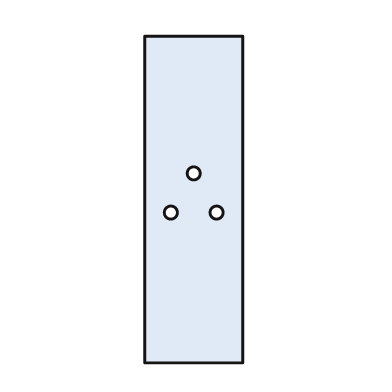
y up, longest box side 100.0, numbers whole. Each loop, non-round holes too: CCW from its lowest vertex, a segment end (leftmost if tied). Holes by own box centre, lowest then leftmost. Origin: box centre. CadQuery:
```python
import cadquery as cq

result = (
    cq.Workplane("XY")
    .moveTo(-15.0, -50.0)
    .lineTo(15.0, -50.0)
    .lineTo(15.0, 50.0)
    .lineTo(-15.0, 50.0)
    .close()
    .moveTo(-7.0, -4.0)
    .circle(2.0)
    .moveTo(7.0, -4.0)
    .circle(2.0)
    .moveTo(0.0, 8.0)
    .circle(2.0)
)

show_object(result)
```